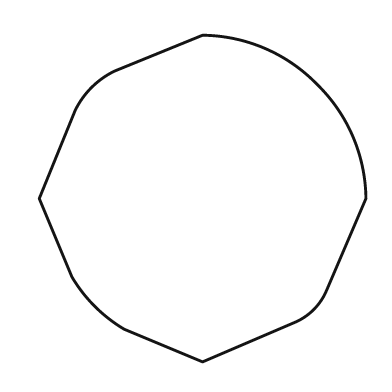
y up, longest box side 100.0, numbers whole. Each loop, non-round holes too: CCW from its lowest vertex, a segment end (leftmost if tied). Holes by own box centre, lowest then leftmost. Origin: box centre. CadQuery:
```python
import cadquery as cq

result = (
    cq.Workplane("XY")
    .moveTo(0.0, -50.0)
    .lineTo(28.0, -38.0)
    .threePointArc((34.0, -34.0), (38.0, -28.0))
    .lineTo(50.0, 0.0)
    .threePointArc((46.0, 19.0), (35.0, 35.0))
    .threePointArc((19.0, 46.0), (0.0, 50.0))
    .lineTo(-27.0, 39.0)
    .threePointArc((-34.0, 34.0), (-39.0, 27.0))
    .lineTo(-50.0, 0.0)
    .lineTo(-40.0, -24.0)
    .threePointArc((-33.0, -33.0), (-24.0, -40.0))
    .close()
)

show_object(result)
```